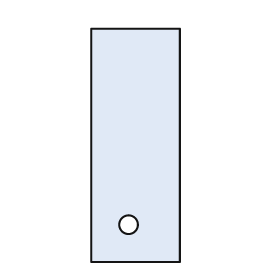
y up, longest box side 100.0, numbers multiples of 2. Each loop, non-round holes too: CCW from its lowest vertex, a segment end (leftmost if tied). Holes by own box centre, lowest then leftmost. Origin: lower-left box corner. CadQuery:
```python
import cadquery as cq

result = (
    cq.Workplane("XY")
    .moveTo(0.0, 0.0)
    .lineTo(38.0, 0.0)
    .lineTo(38.0, 100.0)
    .lineTo(0.0, 100.0)
    .close()
    .moveTo(16.0, 16.0)
    .circle(4.0)
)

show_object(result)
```